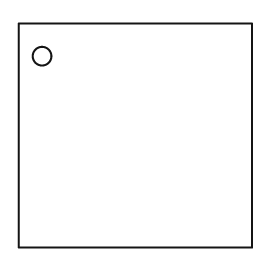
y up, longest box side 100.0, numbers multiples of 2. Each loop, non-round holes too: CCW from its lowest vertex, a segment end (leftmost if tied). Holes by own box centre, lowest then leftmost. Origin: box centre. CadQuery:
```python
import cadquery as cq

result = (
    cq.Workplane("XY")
    .moveTo(-50.0, -48.0)
    .lineTo(50.0, -48.0)
    .lineTo(50.0, 48.0)
    .lineTo(-50.0, 48.0)
    .close()
    .moveTo(-40.0, 34.0)
    .circle(4.0)
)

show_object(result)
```